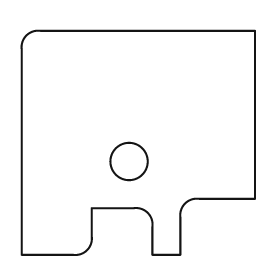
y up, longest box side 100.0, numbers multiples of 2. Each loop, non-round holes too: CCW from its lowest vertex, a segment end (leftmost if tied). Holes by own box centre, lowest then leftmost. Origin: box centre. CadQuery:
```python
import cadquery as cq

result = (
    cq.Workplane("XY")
    .moveTo(-50.0, -48.0)
    .lineTo(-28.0, -48.0)
    .threePointArc((-22.0, -46.0), (-20.0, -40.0))
    .lineTo(-20.0, -28.0)
    .lineTo(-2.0, -28.0)
    .threePointArc((4.0, -30.0), (6.0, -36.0))
    .lineTo(6.0, -48.0)
    .lineTo(18.0, -48.0)
    .lineTo(18.0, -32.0)
    .threePointArc((20.0, -26.0), (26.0, -24.0))
    .lineTo(50.0, -24.0)
    .lineTo(50.0, 48.0)
    .lineTo(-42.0, 48.0)
    .threePointArc((-48.0, 46.0), (-50.0, 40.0))
    .close()
    .moveTo(-4.0, -8.0)
    .circle(8.0)
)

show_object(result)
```